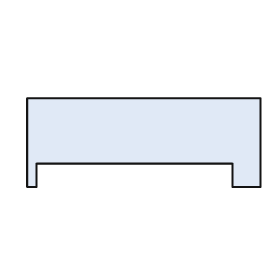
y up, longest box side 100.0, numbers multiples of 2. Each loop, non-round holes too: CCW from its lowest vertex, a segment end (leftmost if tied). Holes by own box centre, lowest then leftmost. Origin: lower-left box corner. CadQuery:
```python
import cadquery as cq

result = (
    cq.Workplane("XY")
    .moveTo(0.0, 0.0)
    .lineTo(4.0, 0.0)
    .lineTo(4.0, 10.0)
    .lineTo(88.0, 10.0)
    .lineTo(88.0, 0.0)
    .lineTo(100.0, 0.0)
    .lineTo(100.0, 38.0)
    .lineTo(0.0, 38.0)
    .close()
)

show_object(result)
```